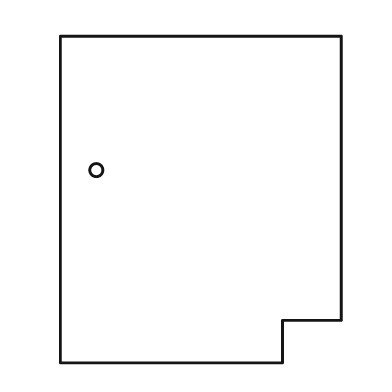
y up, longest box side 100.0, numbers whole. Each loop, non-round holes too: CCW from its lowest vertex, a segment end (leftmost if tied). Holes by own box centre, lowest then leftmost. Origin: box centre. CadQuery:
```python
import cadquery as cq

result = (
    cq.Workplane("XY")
    .moveTo(-43.0, -50.0)
    .lineTo(25.0, -50.0)
    .lineTo(25.0, -37.0)
    .lineTo(43.0, -37.0)
    .lineTo(43.0, 50.0)
    .lineTo(-43.0, 50.0)
    .close()
    .moveTo(-32.0, 9.0)
    .circle(2.0)
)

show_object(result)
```